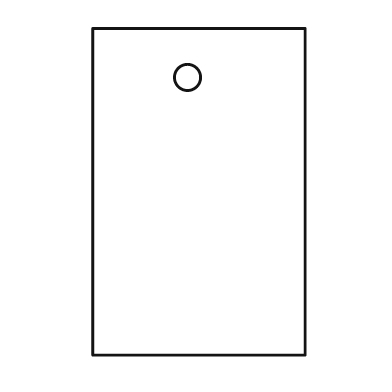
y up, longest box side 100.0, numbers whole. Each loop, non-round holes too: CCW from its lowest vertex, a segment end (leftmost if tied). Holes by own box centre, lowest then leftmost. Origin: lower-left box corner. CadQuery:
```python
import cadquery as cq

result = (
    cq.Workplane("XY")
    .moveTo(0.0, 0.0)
    .lineTo(65.0, 0.0)
    .lineTo(65.0, 100.0)
    .lineTo(0.0, 100.0)
    .close()
    .moveTo(29.0, 85.0)
    .circle(4.0)
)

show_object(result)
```